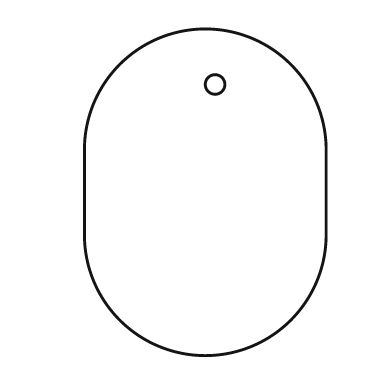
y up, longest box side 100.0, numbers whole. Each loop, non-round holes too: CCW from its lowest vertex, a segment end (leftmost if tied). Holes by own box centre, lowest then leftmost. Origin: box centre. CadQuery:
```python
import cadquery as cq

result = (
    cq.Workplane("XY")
    .moveTo(-37.0, -13.0)
    .threePointArc((0.0, -50.0), (37.0, -13.0))
    .lineTo(37.0, 13.0)
    .threePointArc((0.0, 50.0), (-37.0, 13.0))
    .close()
    .moveTo(3.0, 33.0)
    .circle(3.0)
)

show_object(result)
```